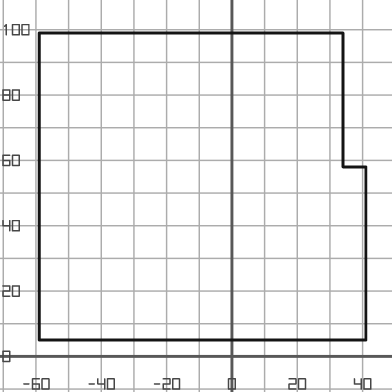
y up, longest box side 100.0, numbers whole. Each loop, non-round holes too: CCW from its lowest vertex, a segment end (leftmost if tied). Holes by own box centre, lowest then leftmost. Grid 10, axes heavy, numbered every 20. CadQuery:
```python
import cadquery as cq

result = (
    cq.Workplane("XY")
    .moveTo(-59.0, 5.0)
    .lineTo(41.0, 5.0)
    .lineTo(41.0, 58.0)
    .lineTo(34.0, 58.0)
    .lineTo(34.0, 99.0)
    .lineTo(-59.0, 99.0)
    .close()
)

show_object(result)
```